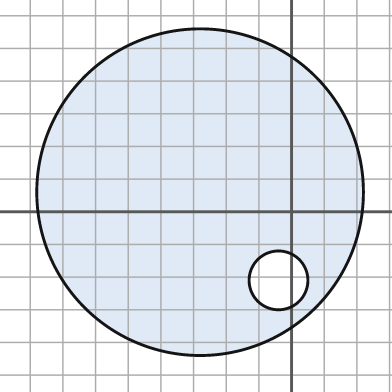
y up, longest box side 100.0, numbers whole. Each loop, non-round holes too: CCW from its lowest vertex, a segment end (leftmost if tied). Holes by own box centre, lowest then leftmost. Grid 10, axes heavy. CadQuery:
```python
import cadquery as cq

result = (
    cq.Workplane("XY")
    .moveTo(-28.0, 6.0)
    .circle(50.0)
    .moveTo(-4.0, -21.0)
    .circle(9.0)
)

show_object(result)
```